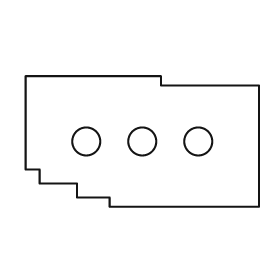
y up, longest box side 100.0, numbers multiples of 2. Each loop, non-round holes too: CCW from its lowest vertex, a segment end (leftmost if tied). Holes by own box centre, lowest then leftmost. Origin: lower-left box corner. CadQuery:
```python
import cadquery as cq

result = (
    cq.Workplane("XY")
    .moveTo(36.0, 0.0)
    .lineTo(100.0, 0.0)
    .lineTo(100.0, 52.0)
    .lineTo(58.0, 52.0)
    .lineTo(58.0, 56.0)
    .lineTo(0.0, 56.0)
    .lineTo(0.0, 16.0)
    .lineTo(6.0, 16.0)
    .lineTo(6.0, 10.0)
    .lineTo(22.0, 10.0)
    .lineTo(22.0, 4.0)
    .lineTo(36.0, 4.0)
    .close()
    .moveTo(26.0, 28.0)
    .circle(6.0)
    .moveTo(50.0, 28.0)
    .circle(6.0)
    .moveTo(74.0, 28.0)
    .circle(6.0)
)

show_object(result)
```